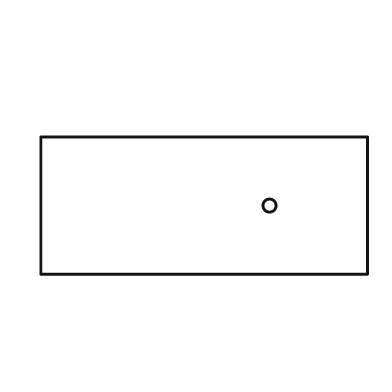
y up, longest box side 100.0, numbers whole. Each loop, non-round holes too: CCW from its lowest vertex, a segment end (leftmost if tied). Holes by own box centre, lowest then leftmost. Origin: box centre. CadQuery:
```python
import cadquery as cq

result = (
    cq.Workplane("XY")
    .moveTo(-50.0, -21.0)
    .lineTo(50.0, -21.0)
    .lineTo(50.0, 21.0)
    .lineTo(-50.0, 21.0)
    .close()
    .moveTo(20.0, 0.0)
    .circle(2.0)
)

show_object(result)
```